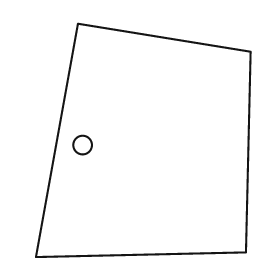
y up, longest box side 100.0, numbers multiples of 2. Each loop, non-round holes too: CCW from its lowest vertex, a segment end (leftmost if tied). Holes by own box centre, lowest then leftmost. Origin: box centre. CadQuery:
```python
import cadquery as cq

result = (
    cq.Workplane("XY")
    .moveTo(-46.0, -50.0)
    .lineTo(44.0, -48.0)
    .lineTo(46.0, 38.0)
    .lineTo(-28.0, 50.0)
    .close()
    .moveTo(-26.0, -2.0)
    .circle(4.0)
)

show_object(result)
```